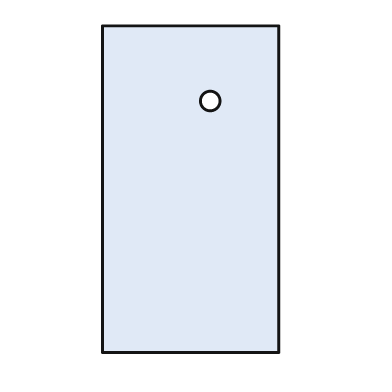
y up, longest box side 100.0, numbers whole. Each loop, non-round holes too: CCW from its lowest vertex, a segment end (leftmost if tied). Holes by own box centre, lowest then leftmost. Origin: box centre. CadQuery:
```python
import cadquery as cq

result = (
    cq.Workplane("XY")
    .moveTo(-27.0, -50.0)
    .lineTo(27.0, -50.0)
    .lineTo(27.0, 50.0)
    .lineTo(-27.0, 50.0)
    .close()
    .moveTo(6.0, 27.0)
    .circle(3.0)
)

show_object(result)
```